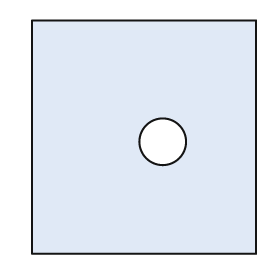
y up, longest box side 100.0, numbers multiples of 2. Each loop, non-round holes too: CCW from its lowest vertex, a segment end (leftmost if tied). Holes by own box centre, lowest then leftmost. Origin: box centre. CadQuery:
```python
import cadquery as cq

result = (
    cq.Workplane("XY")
    .moveTo(-48.0, -50.0)
    .lineTo(48.0, -50.0)
    .lineTo(48.0, 50.0)
    .lineTo(-48.0, 50.0)
    .close()
    .moveTo(8.0, -2.0)
    .circle(10.0)
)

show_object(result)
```